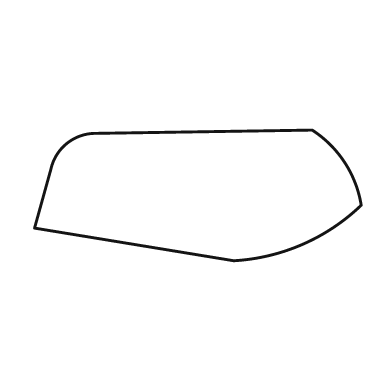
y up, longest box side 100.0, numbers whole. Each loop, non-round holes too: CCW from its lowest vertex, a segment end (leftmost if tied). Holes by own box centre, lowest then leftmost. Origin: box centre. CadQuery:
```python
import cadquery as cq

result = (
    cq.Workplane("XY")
    .moveTo(11.0, -20.0)
    .threePointArc((32.0, -15.0), (50.0, -3.0))
    .threePointArc((45.0, 10.0), (35.0, 20.0))
    .lineTo(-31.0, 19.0)
    .threePointArc((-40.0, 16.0), (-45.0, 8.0))
    .lineTo(-50.0, -10.0)
    .close()
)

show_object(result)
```